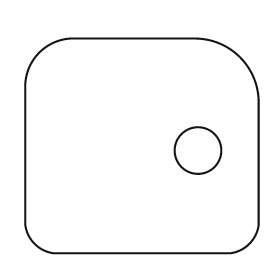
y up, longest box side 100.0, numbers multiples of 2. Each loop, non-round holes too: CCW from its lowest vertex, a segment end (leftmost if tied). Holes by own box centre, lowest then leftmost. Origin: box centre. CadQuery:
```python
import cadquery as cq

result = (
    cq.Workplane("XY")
    .moveTo(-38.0, -46.0)
    .lineTo(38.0, -46.0)
    .threePointArc((46.0, -42.0), (50.0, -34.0))
    .lineTo(50.0, 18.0)
    .threePointArc((42.0, 38.0), (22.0, 46.0))
    .lineTo(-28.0, 46.0)
    .threePointArc((-44.0, 40.0), (-50.0, 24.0))
    .lineTo(-50.0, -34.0)
    .threePointArc((-46.0, -42.0), (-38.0, -46.0))
    .close()
    .moveTo(24.0, -2.0)
    .circle(10.0)
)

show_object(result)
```